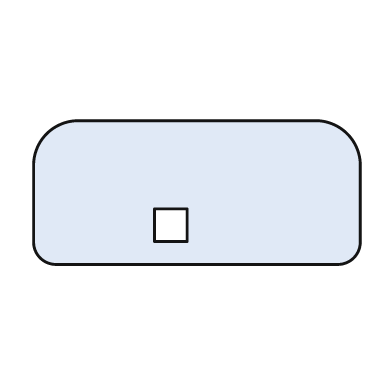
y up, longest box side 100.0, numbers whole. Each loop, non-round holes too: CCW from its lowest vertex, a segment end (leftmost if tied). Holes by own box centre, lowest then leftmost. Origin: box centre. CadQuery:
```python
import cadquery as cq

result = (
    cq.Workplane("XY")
    .moveTo(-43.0, -22.0)
    .lineTo(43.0, -22.0)
    .threePointArc((48.0, -20.0), (50.0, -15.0))
    .lineTo(50.0, 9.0)
    .threePointArc((46.0, 18.0), (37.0, 22.0))
    .lineTo(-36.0, 22.0)
    .threePointArc((-46.0, 18.0), (-50.0, 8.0))
    .lineTo(-50.0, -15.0)
    .threePointArc((-48.0, -20.0), (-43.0, -22.0))
    .close()
    .moveTo(-13.0, -15.0)
    .lineTo(-3.0, -15.0)
    .lineTo(-3.0, -5.0)
    .lineTo(-13.0, -5.0)
    .close()
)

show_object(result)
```